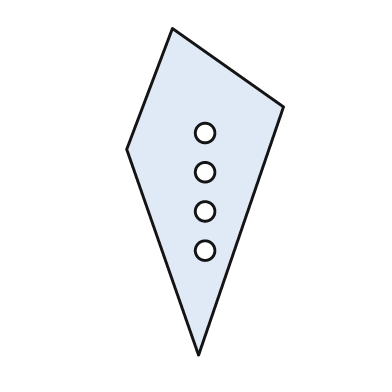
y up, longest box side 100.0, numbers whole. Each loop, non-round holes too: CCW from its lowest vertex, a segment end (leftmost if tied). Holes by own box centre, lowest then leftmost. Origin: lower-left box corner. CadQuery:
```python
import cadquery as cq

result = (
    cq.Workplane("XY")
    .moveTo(22.0, 0.0)
    .lineTo(48.0, 76.0)
    .lineTo(14.0, 100.0)
    .lineTo(0.0, 63.0)
    .close()
    .moveTo(24.0, 32.0)
    .circle(3.0)
    .moveTo(24.0, 44.0)
    .circle(3.0)
    .moveTo(24.0, 56.0)
    .circle(3.0)
    .moveTo(24.0, 68.0)
    .circle(3.0)
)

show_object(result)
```